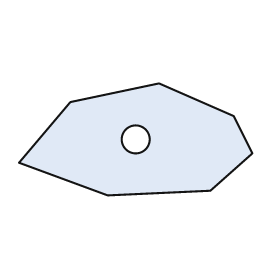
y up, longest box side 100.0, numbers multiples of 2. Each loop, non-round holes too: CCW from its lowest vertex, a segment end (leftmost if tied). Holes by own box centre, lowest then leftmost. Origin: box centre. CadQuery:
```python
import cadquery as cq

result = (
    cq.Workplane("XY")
    .moveTo(-12.0, -24.0)
    .lineTo(32.0, -22.0)
    .lineTo(50.0, -6.0)
    .lineTo(42.0, 10.0)
    .lineTo(10.0, 24.0)
    .lineTo(-28.0, 16.0)
    .lineTo(-50.0, -10.0)
    .close()
    .moveTo(0.0, 0.0)
    .circle(6.0)
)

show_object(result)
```